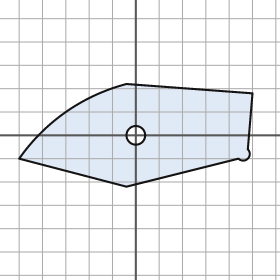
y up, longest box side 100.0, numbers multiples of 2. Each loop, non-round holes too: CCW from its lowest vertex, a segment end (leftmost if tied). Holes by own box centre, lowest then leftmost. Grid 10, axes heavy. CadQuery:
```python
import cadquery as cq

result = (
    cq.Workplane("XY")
    .moveTo(-4.0, -22.0)
    .lineTo(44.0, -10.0)
    .threePointArc((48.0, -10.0), (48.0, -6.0))
    .lineTo(50.0, 18.0)
    .lineTo(-4.0, 22.0)
    .threePointArc((-30.0, 10.0), (-50.0, -10.0))
    .close()
    .moveTo(0.0, 0.0)
    .circle(4.0)
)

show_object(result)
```